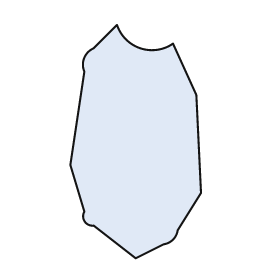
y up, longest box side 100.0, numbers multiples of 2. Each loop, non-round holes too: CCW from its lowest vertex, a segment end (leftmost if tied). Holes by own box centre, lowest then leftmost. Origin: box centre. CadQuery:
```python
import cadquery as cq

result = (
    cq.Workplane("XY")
    .moveTo(0.0, -50.0)
    .lineTo(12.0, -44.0)
    .threePointArc((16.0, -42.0), (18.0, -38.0))
    .lineTo(28.0, -22.0)
    .lineTo(26.0, 20.0)
    .lineTo(16.0, 42.0)
    .threePointArc((2.0, 40.0), (-8.0, 50.0))
    .lineTo(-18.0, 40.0)
    .threePointArc((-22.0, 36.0), (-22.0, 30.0))
    .lineTo(-28.0, -10.0)
    .lineTo(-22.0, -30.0)
    .threePointArc((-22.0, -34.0), (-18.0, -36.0))
    .close()
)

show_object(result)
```